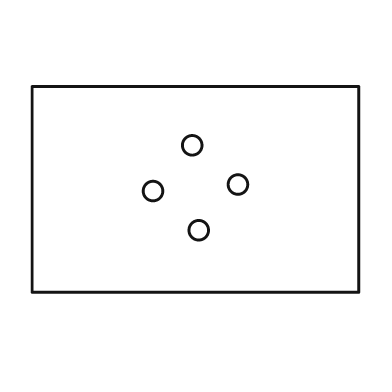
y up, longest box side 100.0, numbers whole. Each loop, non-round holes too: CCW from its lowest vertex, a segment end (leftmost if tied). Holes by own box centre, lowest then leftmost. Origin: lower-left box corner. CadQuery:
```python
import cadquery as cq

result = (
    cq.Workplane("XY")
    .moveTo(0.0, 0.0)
    .lineTo(100.0, 0.0)
    .lineTo(100.0, 63.0)
    .lineTo(0.0, 63.0)
    .close()
    .moveTo(51.0, 19.0)
    .circle(3.0)
    .moveTo(37.0, 31.0)
    .circle(3.0)
    .moveTo(63.0, 33.0)
    .circle(3.0)
    .moveTo(49.0, 45.0)
    .circle(3.0)
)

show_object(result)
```